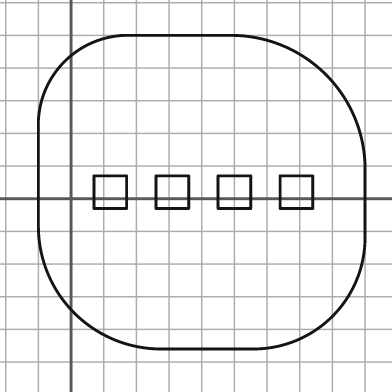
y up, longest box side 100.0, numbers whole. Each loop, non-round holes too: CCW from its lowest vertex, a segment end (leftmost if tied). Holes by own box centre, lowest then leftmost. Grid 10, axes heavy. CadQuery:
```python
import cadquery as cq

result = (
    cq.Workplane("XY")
    .moveTo(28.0, -46.0)
    .lineTo(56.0, -46.0)
    .threePointArc((80.0, -36.0), (90.0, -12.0))
    .lineTo(90.0, 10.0)
    .threePointArc((78.0, 38.0), (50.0, 50.0))
    .lineTo(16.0, 50.0)
    .threePointArc((-2.0, 42.0), (-10.0, 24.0))
    .lineTo(-10.0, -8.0)
    .threePointArc((1.0, -35.0), (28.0, -46.0))
    .close()
    .moveTo(7.0, -3.0)
    .lineTo(17.0, -3.0)
    .lineTo(17.0, 7.0)
    .lineTo(7.0, 7.0)
    .close()
    .moveTo(26.0, -3.0)
    .lineTo(36.0, -3.0)
    .lineTo(36.0, 7.0)
    .lineTo(26.0, 7.0)
    .close()
    .moveTo(45.0, -3.0)
    .lineTo(55.0, -3.0)
    .lineTo(55.0, 7.0)
    .lineTo(45.0, 7.0)
    .close()
    .moveTo(64.0, -3.0)
    .lineTo(74.0, -3.0)
    .lineTo(74.0, 7.0)
    .lineTo(64.0, 7.0)
    .close()
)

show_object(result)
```